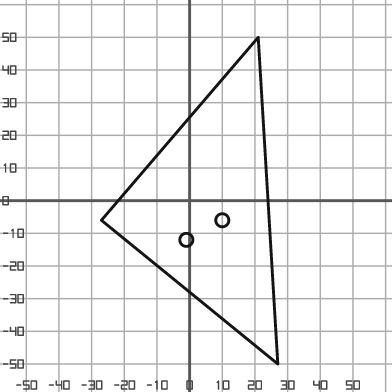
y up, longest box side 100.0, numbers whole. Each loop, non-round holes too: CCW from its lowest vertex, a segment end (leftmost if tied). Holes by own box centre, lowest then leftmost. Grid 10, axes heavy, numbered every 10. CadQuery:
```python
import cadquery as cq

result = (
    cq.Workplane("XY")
    .moveTo(27.0, -50.0)
    .lineTo(21.0, 50.0)
    .lineTo(-27.0, -6.0)
    .close()
    .moveTo(-1.0, -12.0)
    .circle(2.0)
    .moveTo(10.0, -6.0)
    .circle(2.0)
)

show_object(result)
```